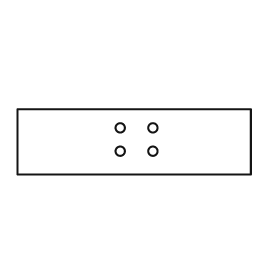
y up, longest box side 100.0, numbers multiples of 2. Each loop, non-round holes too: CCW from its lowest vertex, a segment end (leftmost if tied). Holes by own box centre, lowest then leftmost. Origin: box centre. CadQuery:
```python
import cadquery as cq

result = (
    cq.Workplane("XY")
    .moveTo(-50.0, -14.0)
    .lineTo(50.0, -14.0)
    .lineTo(50.0, 14.0)
    .lineTo(-50.0, 14.0)
    .close()
    .moveTo(-6.0, -4.0)
    .circle(2.0)
    .moveTo(8.0, -4.0)
    .circle(2.0)
    .moveTo(-6.0, 6.0)
    .circle(2.0)
    .moveTo(8.0, 6.0)
    .circle(2.0)
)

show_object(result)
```